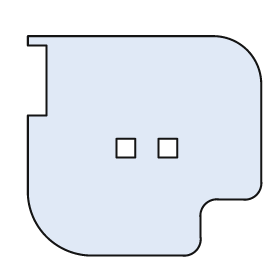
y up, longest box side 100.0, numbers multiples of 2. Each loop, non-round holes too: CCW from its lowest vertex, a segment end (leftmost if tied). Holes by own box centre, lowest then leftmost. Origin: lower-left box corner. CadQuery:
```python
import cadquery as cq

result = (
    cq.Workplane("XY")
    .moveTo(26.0, 0.0)
    .lineTo(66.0, 0.0)
    .threePointArc((72.0, 2.0), (74.0, 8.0))
    .lineTo(74.0, 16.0)
    .threePointArc((76.0, 22.0), (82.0, 24.0))
    .lineTo(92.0, 24.0)
    .threePointArc((98.0, 26.0), (100.0, 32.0))
    .lineTo(100.0, 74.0)
    .threePointArc((94.0, 88.0), (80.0, 94.0))
    .lineTo(0.0, 94.0)
    .lineTo(0.0, 90.0)
    .lineTo(8.0, 90.0)
    .lineTo(8.0, 60.0)
    .lineTo(0.0, 60.0)
    .lineTo(0.0, 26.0)
    .threePointArc((8.0, 8.0), (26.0, 0.0))
    .close()
    .moveTo(38.0, 42.0)
    .lineTo(46.0, 42.0)
    .lineTo(46.0, 50.0)
    .lineTo(38.0, 50.0)
    .close()
    .moveTo(56.0, 42.0)
    .lineTo(64.0, 42.0)
    .lineTo(64.0, 50.0)
    .lineTo(56.0, 50.0)
    .close()
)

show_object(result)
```